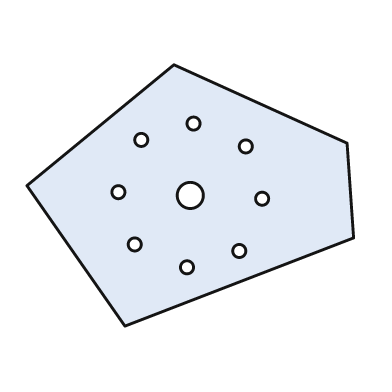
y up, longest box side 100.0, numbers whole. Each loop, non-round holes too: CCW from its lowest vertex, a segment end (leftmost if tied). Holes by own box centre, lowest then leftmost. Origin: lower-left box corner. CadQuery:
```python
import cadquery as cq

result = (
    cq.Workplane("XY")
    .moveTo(30.0, 0.0)
    .lineTo(100.0, 27.0)
    .lineTo(98.0, 56.0)
    .lineTo(45.0, 80.0)
    .lineTo(0.0, 43.0)
    .close()
    .moveTo(49.0, 18.0)
    .circle(2.0)
    .moveTo(65.0, 23.0)
    .circle(2.0)
    .moveTo(33.0, 25.0)
    .circle(2.0)
    .moveTo(72.0, 39.0)
    .circle(2.0)
    .moveTo(50.0, 40.0)
    .circle(4.0)
    .moveTo(28.0, 41.0)
    .circle(2.0)
    .moveTo(67.0, 55.0)
    .circle(2.0)
    .moveTo(35.0, 57.0)
    .circle(2.0)
    .moveTo(51.0, 62.0)
    .circle(2.0)
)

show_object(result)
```